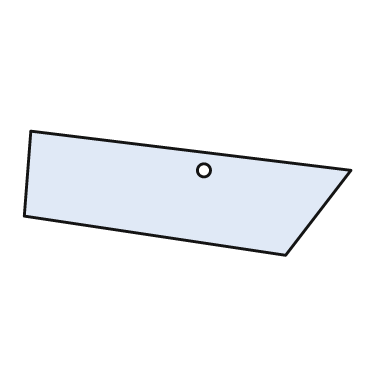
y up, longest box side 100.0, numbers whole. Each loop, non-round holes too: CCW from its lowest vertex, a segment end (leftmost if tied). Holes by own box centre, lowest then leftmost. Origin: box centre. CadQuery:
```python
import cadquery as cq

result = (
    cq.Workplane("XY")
    .moveTo(30.0, -19.0)
    .lineTo(50.0, 7.0)
    .lineTo(-48.0, 19.0)
    .lineTo(-50.0, -7.0)
    .close()
    .moveTo(5.0, 7.0)
    .circle(2.0)
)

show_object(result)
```